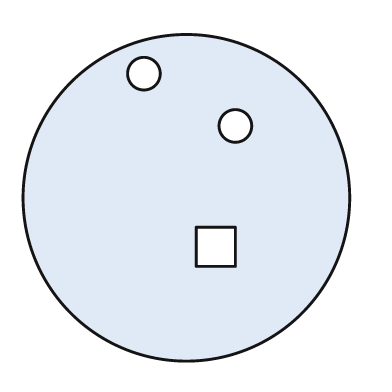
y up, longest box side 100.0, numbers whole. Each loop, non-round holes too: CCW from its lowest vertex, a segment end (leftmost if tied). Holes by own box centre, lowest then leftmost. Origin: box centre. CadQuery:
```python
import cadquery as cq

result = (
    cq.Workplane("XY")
    .moveTo(0.0, 0.0)
    .circle(50.0)
    .moveTo(3.0, -21.0)
    .lineTo(15.0, -21.0)
    .lineTo(15.0, -9.0)
    .lineTo(3.0, -9.0)
    .close()
    .moveTo(15.0, 22.0)
    .circle(5.0)
    .moveTo(-13.0, 38.0)
    .circle(5.0)
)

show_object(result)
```